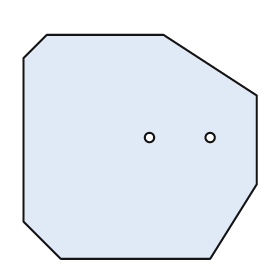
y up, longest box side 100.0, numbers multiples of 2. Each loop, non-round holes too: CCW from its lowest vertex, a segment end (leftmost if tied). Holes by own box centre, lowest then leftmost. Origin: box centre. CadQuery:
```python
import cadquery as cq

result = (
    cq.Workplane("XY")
    .moveTo(-34.0, -48.0)
    .lineTo(30.0, -48.0)
    .lineTo(50.0, -16.0)
    .lineTo(50.0, 22.0)
    .lineTo(10.0, 48.0)
    .lineTo(-40.0, 48.0)
    .lineTo(-50.0, 38.0)
    .lineTo(-50.0, -32.0)
    .close()
    .moveTo(4.0, 4.0)
    .circle(2.0)
    .moveTo(30.0, 4.0)
    .circle(2.0)
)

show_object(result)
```